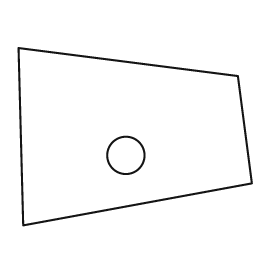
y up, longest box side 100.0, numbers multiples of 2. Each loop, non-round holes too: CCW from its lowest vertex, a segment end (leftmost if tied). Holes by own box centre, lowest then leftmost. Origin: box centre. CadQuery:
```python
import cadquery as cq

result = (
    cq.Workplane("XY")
    .moveTo(-48.0, -38.0)
    .lineTo(50.0, -20.0)
    .lineTo(44.0, 26.0)
    .lineTo(-50.0, 38.0)
    .close()
    .moveTo(-4.0, -8.0)
    .circle(8.0)
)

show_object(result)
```